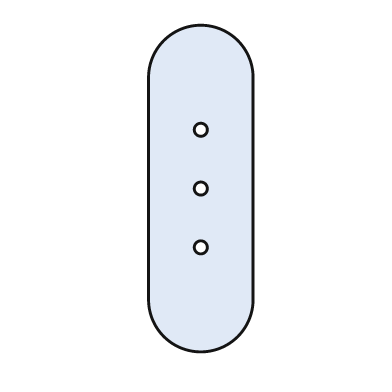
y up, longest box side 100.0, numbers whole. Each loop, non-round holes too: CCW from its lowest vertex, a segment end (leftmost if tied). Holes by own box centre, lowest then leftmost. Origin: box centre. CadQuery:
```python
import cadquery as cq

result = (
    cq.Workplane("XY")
    .moveTo(-16.0, -34.0)
    .threePointArc((0.0, -50.0), (16.0, -34.0))
    .lineTo(16.0, 34.0)
    .threePointArc((0.0, 50.0), (-16.0, 34.0))
    .close()
    .moveTo(0.0, -18.0)
    .circle(2.0)
    .moveTo(0.0, 0.0)
    .circle(2.0)
    .moveTo(0.0, 18.0)
    .circle(2.0)
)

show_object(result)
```